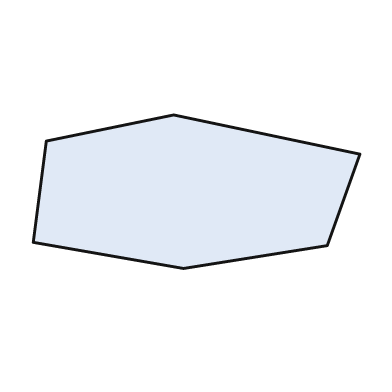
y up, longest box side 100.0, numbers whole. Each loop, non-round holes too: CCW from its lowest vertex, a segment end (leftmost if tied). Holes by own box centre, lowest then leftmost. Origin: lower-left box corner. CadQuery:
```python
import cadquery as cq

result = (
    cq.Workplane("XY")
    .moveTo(46.0, 0.0)
    .lineTo(90.0, 7.0)
    .lineTo(100.0, 35.0)
    .lineTo(43.0, 47.0)
    .lineTo(4.0, 39.0)
    .lineTo(0.0, 8.0)
    .close()
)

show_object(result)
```